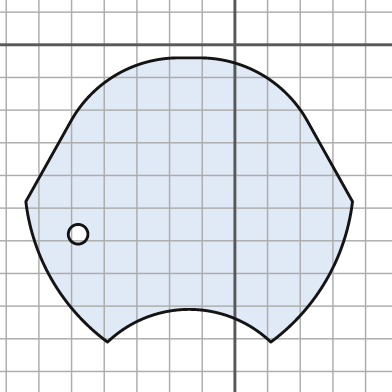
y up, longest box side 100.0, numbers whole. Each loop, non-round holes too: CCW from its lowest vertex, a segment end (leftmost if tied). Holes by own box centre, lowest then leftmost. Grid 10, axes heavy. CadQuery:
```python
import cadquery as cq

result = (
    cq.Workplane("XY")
    .moveTo(-39.0, -91.0)
    .threePointArc((-14.0, -81.0), (11.0, -91.0))
    .threePointArc((28.0, -72.0), (36.0, -48.0))
    .lineTo(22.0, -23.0)
    .threePointArc((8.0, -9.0), (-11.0, -4.0))
    .lineTo(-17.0, -4.0)
    .threePointArc((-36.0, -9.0), (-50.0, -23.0))
    .lineTo(-64.0, -48.0)
    .threePointArc((-56.0, -72.0), (-39.0, -91.0))
    .close()
    .moveTo(-48.0, -58.0)
    .circle(3.0)
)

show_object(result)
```